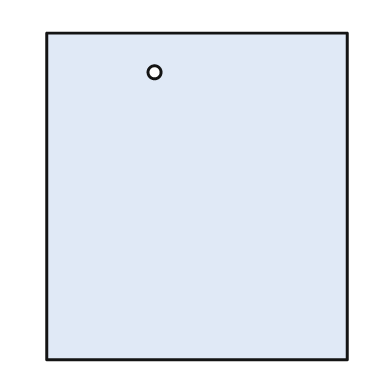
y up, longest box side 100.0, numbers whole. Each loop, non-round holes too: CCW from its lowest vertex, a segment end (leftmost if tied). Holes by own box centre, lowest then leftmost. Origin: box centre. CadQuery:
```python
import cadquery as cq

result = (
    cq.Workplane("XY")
    .moveTo(-46.0, -50.0)
    .lineTo(46.0, -50.0)
    .lineTo(46.0, 50.0)
    .lineTo(-46.0, 50.0)
    .close()
    .moveTo(-13.0, 38.0)
    .circle(2.0)
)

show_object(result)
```